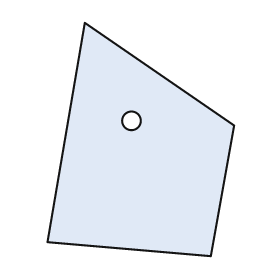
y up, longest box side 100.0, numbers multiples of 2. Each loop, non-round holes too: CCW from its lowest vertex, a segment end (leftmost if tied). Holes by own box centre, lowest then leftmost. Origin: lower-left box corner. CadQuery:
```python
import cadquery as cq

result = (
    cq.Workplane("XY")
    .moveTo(70.0, 0.0)
    .lineTo(80.0, 56.0)
    .lineTo(16.0, 100.0)
    .lineTo(0.0, 6.0)
    .close()
    .moveTo(36.0, 58.0)
    .circle(4.0)
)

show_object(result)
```